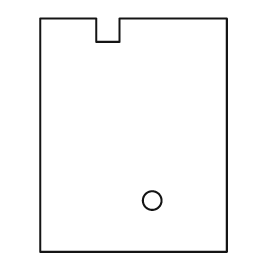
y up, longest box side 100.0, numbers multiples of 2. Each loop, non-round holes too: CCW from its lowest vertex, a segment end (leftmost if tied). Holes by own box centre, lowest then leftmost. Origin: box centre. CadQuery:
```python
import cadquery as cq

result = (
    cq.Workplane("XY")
    .moveTo(-40.0, -50.0)
    .lineTo(40.0, -50.0)
    .lineTo(40.0, 50.0)
    .lineTo(-6.0, 50.0)
    .lineTo(-6.0, 40.0)
    .lineTo(-16.0, 40.0)
    .lineTo(-16.0, 50.0)
    .lineTo(-40.0, 50.0)
    .close()
    .moveTo(8.0, -28.0)
    .circle(4.0)
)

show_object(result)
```